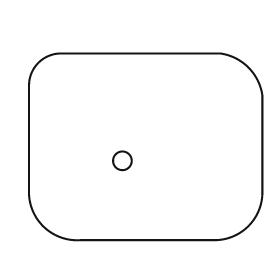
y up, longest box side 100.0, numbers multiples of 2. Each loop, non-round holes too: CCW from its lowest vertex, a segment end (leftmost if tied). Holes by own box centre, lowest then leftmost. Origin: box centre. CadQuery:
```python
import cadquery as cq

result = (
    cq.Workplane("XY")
    .moveTo(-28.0, -40.0)
    .lineTo(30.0, -40.0)
    .threePointArc((44.0, -34.0), (50.0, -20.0))
    .lineTo(50.0, 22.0)
    .threePointArc((44.0, 34.0), (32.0, 40.0))
    .lineTo(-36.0, 40.0)
    .threePointArc((-46.0, 36.0), (-50.0, 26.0))
    .lineTo(-50.0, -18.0)
    .threePointArc((-44.0, -34.0), (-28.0, -40.0))
    .close()
    .moveTo(-10.0, -6.0)
    .circle(4.0)
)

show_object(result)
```